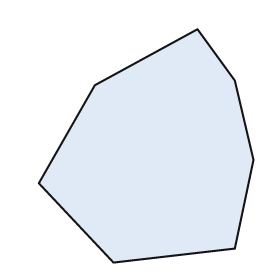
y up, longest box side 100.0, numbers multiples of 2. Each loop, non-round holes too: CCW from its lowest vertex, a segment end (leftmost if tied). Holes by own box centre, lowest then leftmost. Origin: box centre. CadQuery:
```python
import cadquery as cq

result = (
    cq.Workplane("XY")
    .moveTo(-14.0, -50.0)
    .lineTo(38.0, -44.0)
    .lineTo(46.0, -6.0)
    .lineTo(38.0, 28.0)
    .lineTo(22.0, 50.0)
    .lineTo(-22.0, 26.0)
    .lineTo(-46.0, -16.0)
    .close()
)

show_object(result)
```